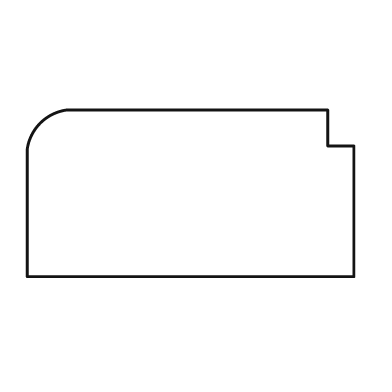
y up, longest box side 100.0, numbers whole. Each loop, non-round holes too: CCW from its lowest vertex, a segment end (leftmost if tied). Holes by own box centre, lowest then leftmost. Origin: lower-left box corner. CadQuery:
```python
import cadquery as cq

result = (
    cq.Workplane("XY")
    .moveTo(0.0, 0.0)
    .lineTo(100.0, 0.0)
    .lineTo(100.0, 40.0)
    .lineTo(92.0, 40.0)
    .lineTo(92.0, 51.0)
    .lineTo(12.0, 51.0)
    .threePointArc((4.0, 47.0), (0.0, 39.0))
    .close()
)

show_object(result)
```